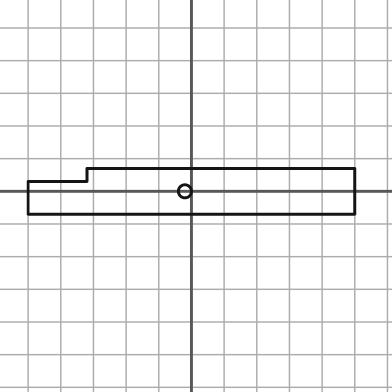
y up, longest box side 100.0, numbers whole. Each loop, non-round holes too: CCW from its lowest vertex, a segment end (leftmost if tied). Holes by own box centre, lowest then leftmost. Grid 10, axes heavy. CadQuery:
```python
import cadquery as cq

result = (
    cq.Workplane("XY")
    .moveTo(-50.0, -7.0)
    .lineTo(50.0, -7.0)
    .lineTo(50.0, 7.0)
    .lineTo(-32.0, 7.0)
    .lineTo(-32.0, 3.0)
    .lineTo(-50.0, 3.0)
    .close()
    .moveTo(-2.0, 0.0)
    .circle(2.0)
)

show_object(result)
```